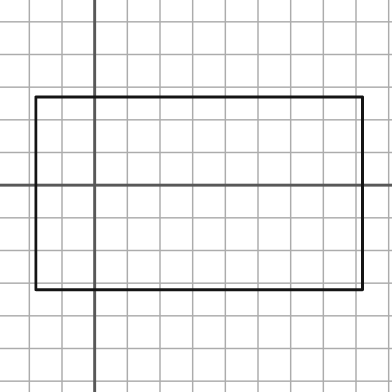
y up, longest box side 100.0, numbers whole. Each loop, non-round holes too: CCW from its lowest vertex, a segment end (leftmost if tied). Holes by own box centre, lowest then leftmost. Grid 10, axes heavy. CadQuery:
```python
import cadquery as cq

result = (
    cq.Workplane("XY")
    .moveTo(-18.0, -32.0)
    .lineTo(82.0, -32.0)
    .lineTo(82.0, 27.0)
    .lineTo(-18.0, 27.0)
    .close()
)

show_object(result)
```